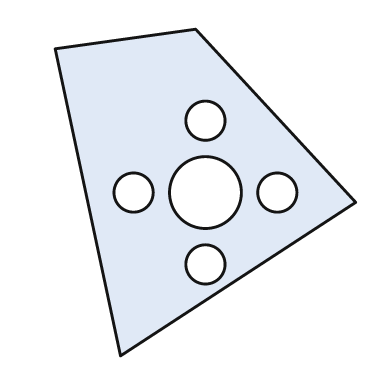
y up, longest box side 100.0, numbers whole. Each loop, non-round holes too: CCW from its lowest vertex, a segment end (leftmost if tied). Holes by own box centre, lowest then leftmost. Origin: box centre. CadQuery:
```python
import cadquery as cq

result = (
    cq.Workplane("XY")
    .moveTo(-26.0, -50.0)
    .lineTo(46.0, -3.0)
    .lineTo(-3.0, 50.0)
    .lineTo(-46.0, 44.0)
    .close()
    .moveTo(0.0, -22.0)
    .circle(6.0)
    .moveTo(-22.0, 0.0)
    .circle(6.0)
    .moveTo(0.0, 0.0)
    .circle(11.0)
    .moveTo(22.0, 0.0)
    .circle(6.0)
    .moveTo(0.0, 22.0)
    .circle(6.0)
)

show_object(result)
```